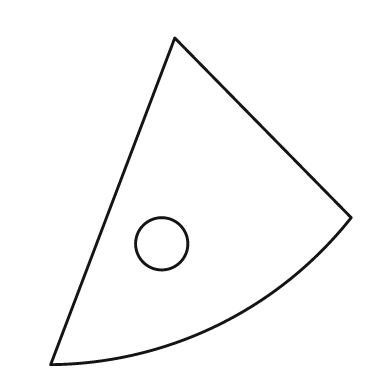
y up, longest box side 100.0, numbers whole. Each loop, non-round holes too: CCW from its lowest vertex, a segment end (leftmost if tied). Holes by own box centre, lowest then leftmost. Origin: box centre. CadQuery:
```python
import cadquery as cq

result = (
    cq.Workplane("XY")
    .moveTo(-46.0, -50.0)
    .threePointArc((5.0, -38.0), (46.0, -5.0))
    .lineTo(-8.0, 50.0)
    .close()
    .moveTo(-12.0, -13.0)
    .circle(8.0)
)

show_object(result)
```